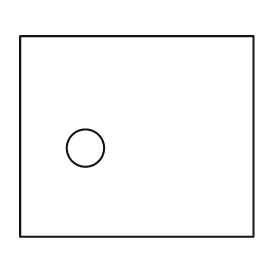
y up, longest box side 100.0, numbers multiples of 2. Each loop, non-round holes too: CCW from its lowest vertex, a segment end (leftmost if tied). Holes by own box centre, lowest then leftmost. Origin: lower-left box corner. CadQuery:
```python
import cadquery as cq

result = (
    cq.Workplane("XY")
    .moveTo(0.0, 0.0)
    .lineTo(100.0, 0.0)
    .lineTo(100.0, 86.0)
    .lineTo(0.0, 86.0)
    .close()
    .moveTo(28.0, 38.0)
    .circle(8.0)
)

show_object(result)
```